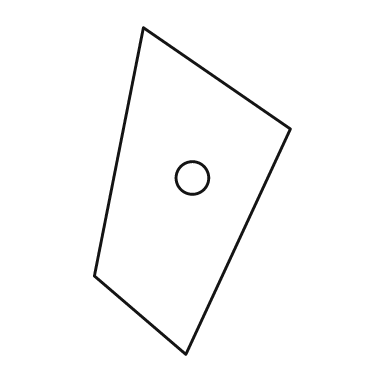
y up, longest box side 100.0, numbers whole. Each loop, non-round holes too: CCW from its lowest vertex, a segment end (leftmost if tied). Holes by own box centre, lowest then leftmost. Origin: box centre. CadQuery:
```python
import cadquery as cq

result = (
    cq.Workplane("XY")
    .moveTo(-2.0, -50.0)
    .lineTo(30.0, 19.0)
    .lineTo(-15.0, 50.0)
    .lineTo(-30.0, -26.0)
    .close()
    .moveTo(0.0, 4.0)
    .circle(5.0)
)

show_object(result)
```